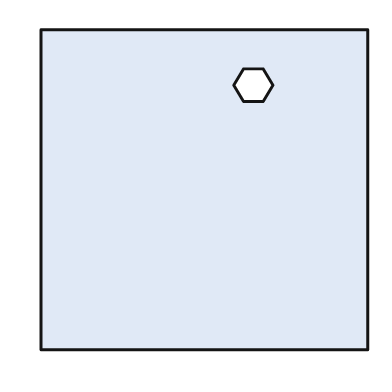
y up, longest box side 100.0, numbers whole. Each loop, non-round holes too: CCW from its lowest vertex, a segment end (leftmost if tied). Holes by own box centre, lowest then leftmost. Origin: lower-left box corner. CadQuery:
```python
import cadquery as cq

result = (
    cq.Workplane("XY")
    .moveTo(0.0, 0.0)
    .lineTo(100.0, 0.0)
    .lineTo(100.0, 98.0)
    .lineTo(0.0, 98.0)
    .close()
    .moveTo(62.0, 76.0)
    .lineTo(68.0, 76.0)
    .lineTo(71.0, 81.0)
    .lineTo(68.0, 86.0)
    .lineTo(62.0, 86.0)
    .lineTo(59.0, 81.0)
    .close()
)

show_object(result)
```